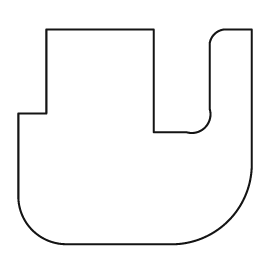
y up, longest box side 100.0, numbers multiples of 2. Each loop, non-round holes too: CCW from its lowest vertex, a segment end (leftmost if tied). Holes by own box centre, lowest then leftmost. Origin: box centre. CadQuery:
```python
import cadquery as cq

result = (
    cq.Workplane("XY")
    .moveTo(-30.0, -46.0)
    .lineTo(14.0, -46.0)
    .threePointArc((40.0, -36.0), (50.0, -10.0))
    .lineTo(50.0, 46.0)
    .lineTo(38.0, 46.0)
    .threePointArc((34.0, 44.0), (32.0, 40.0))
    .lineTo(32.0, 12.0)
    .threePointArc((30.0, 4.0), (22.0, 2.0))
    .lineTo(8.0, 2.0)
    .lineTo(8.0, 46.0)
    .lineTo(-38.0, 46.0)
    .lineTo(-38.0, 10.0)
    .lineTo(-50.0, 10.0)
    .lineTo(-50.0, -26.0)
    .threePointArc((-44.0, -40.0), (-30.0, -46.0))
    .close()
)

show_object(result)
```